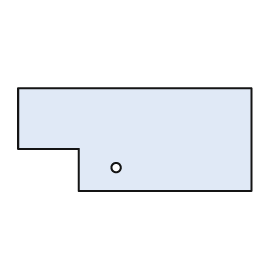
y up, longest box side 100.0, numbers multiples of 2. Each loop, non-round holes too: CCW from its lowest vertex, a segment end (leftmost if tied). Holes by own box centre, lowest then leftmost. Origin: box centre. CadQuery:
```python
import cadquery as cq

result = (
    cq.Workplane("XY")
    .moveTo(-24.0, -22.0)
    .lineTo(50.0, -22.0)
    .lineTo(50.0, 22.0)
    .lineTo(-50.0, 22.0)
    .lineTo(-50.0, -4.0)
    .lineTo(-24.0, -4.0)
    .close()
    .moveTo(-8.0, -12.0)
    .circle(2.0)
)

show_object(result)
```